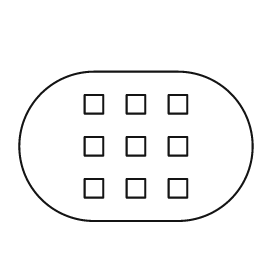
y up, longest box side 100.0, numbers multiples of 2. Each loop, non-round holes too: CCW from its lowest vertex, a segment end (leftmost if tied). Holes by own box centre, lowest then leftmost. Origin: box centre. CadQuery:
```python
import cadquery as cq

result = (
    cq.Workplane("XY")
    .moveTo(-18.0, -32.0)
    .lineTo(18.0, -32.0)
    .threePointArc((50.0, 0.0), (18.0, 32.0))
    .lineTo(-18.0, 32.0)
    .threePointArc((-50.0, 0.0), (-18.0, -32.0))
    .close()
    .moveTo(-22.0, -22.0)
    .lineTo(-14.0, -22.0)
    .lineTo(-14.0, -14.0)
    .lineTo(-22.0, -14.0)
    .close()
    .moveTo(-4.0, -22.0)
    .lineTo(4.0, -22.0)
    .lineTo(4.0, -14.0)
    .lineTo(-4.0, -14.0)
    .close()
    .moveTo(14.0, -22.0)
    .lineTo(22.0, -22.0)
    .lineTo(22.0, -14.0)
    .lineTo(14.0, -14.0)
    .close()
    .moveTo(-22.0, -4.0)
    .lineTo(-14.0, -4.0)
    .lineTo(-14.0, 4.0)
    .lineTo(-22.0, 4.0)
    .close()
    .moveTo(-4.0, -4.0)
    .lineTo(4.0, -4.0)
    .lineTo(4.0, 4.0)
    .lineTo(-4.0, 4.0)
    .close()
    .moveTo(14.0, -4.0)
    .lineTo(22.0, -4.0)
    .lineTo(22.0, 4.0)
    .lineTo(14.0, 4.0)
    .close()
    .moveTo(-22.0, 14.0)
    .lineTo(-14.0, 14.0)
    .lineTo(-14.0, 22.0)
    .lineTo(-22.0, 22.0)
    .close()
    .moveTo(-4.0, 14.0)
    .lineTo(4.0, 14.0)
    .lineTo(4.0, 22.0)
    .lineTo(-4.0, 22.0)
    .close()
    .moveTo(14.0, 14.0)
    .lineTo(22.0, 14.0)
    .lineTo(22.0, 22.0)
    .lineTo(14.0, 22.0)
    .close()
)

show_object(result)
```